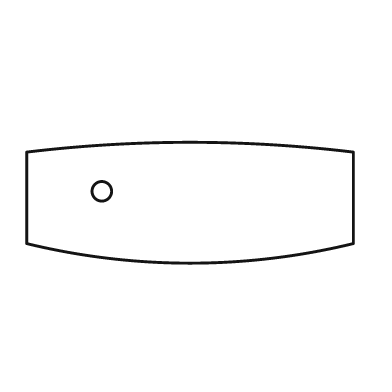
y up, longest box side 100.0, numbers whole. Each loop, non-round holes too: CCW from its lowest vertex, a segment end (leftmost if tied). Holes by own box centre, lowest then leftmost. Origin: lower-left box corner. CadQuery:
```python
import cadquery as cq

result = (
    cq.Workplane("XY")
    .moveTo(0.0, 6.0)
    .threePointArc((50.0, 0.0), (100.0, 6.0))
    .lineTo(100.0, 34.0)
    .threePointArc((50.0, 37.0), (0.0, 34.0))
    .close()
    .moveTo(23.0, 22.0)
    .circle(3.0)
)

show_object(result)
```